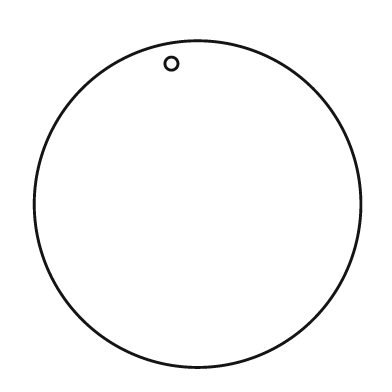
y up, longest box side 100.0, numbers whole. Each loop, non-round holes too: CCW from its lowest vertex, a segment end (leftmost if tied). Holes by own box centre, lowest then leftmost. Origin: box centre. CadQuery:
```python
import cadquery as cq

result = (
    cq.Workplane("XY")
    .moveTo(0.0, 0.0)
    .circle(50.0)
    .moveTo(-8.0, 43.0)
    .circle(2.0)
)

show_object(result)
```